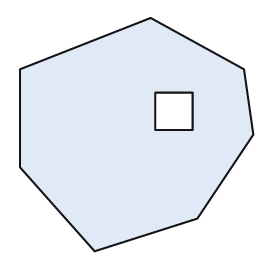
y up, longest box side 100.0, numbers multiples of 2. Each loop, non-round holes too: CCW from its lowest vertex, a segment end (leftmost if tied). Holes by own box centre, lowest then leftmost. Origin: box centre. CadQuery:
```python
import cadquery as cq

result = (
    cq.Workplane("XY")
    .moveTo(-18.0, -50.0)
    .lineTo(26.0, -36.0)
    .lineTo(50.0, 0.0)
    .lineTo(46.0, 28.0)
    .lineTo(6.0, 50.0)
    .lineTo(-50.0, 28.0)
    .lineTo(-50.0, -14.0)
    .close()
    .moveTo(8.0, 2.0)
    .lineTo(24.0, 2.0)
    .lineTo(24.0, 18.0)
    .lineTo(8.0, 18.0)
    .close()
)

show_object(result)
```